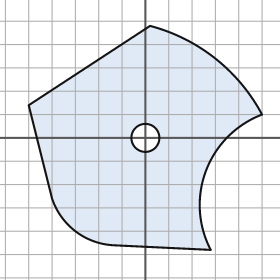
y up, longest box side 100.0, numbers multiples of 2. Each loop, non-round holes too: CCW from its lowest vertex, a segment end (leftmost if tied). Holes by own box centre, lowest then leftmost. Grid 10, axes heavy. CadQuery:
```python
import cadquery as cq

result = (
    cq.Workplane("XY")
    .moveTo(28.0, -48.0)
    .threePointArc((26.0, -14.0), (50.0, 10.0))
    .threePointArc((30.0, 34.0), (2.0, 48.0))
    .lineTo(-50.0, 14.0)
    .lineTo(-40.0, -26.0)
    .threePointArc((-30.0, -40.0), (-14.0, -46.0))
    .close()
    .moveTo(0.0, 0.0)
    .circle(6.0)
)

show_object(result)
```